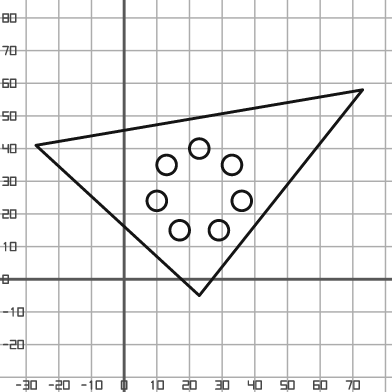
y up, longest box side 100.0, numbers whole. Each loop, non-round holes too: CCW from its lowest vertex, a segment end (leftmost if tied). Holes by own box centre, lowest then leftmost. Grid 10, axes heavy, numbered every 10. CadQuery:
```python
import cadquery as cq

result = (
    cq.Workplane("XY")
    .moveTo(23.0, -5.0)
    .lineTo(73.0, 58.0)
    .lineTo(-27.0, 41.0)
    .close()
    .moveTo(17.0, 15.0)
    .circle(3.0)
    .moveTo(29.0, 15.0)
    .circle(3.0)
    .moveTo(10.0, 24.0)
    .circle(3.0)
    .moveTo(36.0, 24.0)
    .circle(3.0)
    .moveTo(13.0, 35.0)
    .circle(3.0)
    .moveTo(33.0, 35.0)
    .circle(3.0)
    .moveTo(23.0, 40.0)
    .circle(3.0)
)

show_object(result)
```